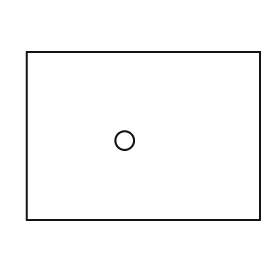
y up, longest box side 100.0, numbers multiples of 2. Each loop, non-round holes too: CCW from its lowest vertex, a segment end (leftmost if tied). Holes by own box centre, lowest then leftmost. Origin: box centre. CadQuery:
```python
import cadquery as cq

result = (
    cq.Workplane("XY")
    .moveTo(-50.0, -36.0)
    .lineTo(50.0, -36.0)
    .lineTo(50.0, 36.0)
    .lineTo(-50.0, 36.0)
    .close()
    .moveTo(-8.0, -2.0)
    .circle(4.0)
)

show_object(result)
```